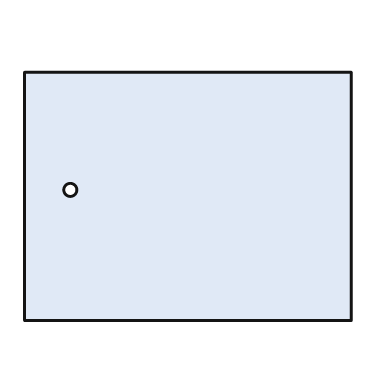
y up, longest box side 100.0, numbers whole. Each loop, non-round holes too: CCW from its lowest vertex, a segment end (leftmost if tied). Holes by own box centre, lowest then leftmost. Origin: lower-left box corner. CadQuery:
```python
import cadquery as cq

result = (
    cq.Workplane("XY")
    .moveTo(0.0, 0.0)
    .lineTo(100.0, 0.0)
    .lineTo(100.0, 76.0)
    .lineTo(0.0, 76.0)
    .close()
    .moveTo(14.0, 40.0)
    .circle(2.0)
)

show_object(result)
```